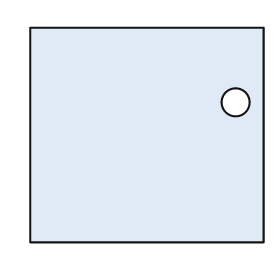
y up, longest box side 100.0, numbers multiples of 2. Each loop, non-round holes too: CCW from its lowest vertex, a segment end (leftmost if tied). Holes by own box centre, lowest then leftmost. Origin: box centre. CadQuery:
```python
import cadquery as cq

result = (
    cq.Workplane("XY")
    .moveTo(-50.0, -46.0)
    .lineTo(50.0, -46.0)
    .lineTo(50.0, 46.0)
    .lineTo(-50.0, 46.0)
    .close()
    .moveTo(38.0, 14.0)
    .circle(6.0)
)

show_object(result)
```